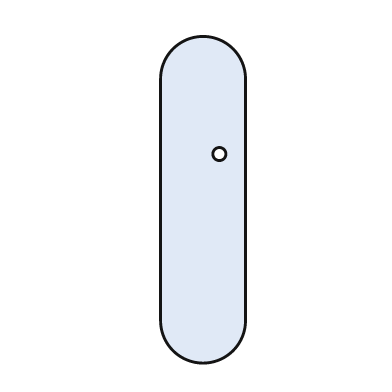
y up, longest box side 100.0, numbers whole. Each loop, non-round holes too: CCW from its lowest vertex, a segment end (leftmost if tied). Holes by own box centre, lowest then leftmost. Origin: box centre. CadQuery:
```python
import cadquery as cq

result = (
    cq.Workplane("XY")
    .moveTo(-13.0, -37.0)
    .threePointArc((0.0, -50.0), (13.0, -37.0))
    .lineTo(13.0, 37.0)
    .threePointArc((0.0, 50.0), (-13.0, 37.0))
    .close()
    .moveTo(5.0, 14.0)
    .circle(2.0)
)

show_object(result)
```